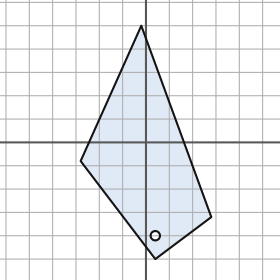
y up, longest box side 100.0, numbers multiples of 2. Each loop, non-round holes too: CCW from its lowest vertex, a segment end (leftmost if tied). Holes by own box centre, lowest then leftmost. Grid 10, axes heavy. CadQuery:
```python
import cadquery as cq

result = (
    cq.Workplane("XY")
    .moveTo(4.0, -50.0)
    .lineTo(28.0, -32.0)
    .lineTo(-2.0, 50.0)
    .lineTo(-28.0, -8.0)
    .close()
    .moveTo(4.0, -40.0)
    .circle(2.0)
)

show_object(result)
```